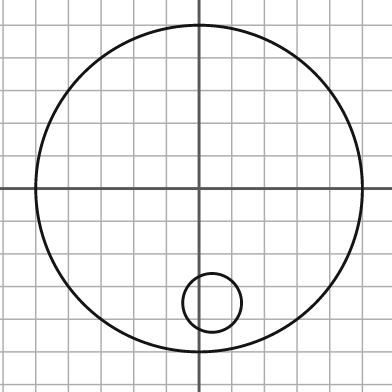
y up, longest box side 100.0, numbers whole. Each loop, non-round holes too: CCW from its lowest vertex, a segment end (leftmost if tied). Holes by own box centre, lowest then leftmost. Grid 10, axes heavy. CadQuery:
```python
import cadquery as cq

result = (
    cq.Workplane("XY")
    .moveTo(0.0, 0.0)
    .circle(50.0)
    .moveTo(4.0, -35.0)
    .circle(9.0)
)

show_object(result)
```